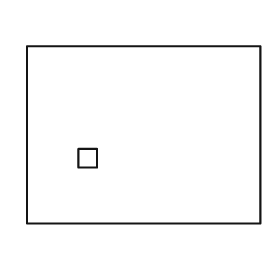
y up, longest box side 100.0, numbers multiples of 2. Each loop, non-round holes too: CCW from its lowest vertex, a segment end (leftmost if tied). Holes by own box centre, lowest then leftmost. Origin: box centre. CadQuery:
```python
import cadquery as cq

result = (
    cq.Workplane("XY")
    .moveTo(-50.0, -38.0)
    .lineTo(50.0, -38.0)
    .lineTo(50.0, 38.0)
    .lineTo(-50.0, 38.0)
    .close()
    .moveTo(-28.0, -14.0)
    .lineTo(-20.0, -14.0)
    .lineTo(-20.0, -6.0)
    .lineTo(-28.0, -6.0)
    .close()
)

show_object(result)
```